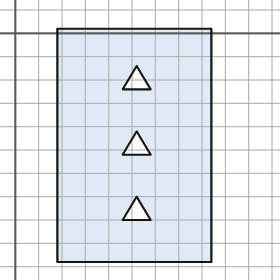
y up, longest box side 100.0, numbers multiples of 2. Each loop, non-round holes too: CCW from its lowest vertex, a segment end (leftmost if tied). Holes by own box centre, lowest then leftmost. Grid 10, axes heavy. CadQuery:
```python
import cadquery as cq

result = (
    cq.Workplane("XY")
    .moveTo(18.0, -98.0)
    .lineTo(84.0, -98.0)
    .lineTo(84.0, 2.0)
    .lineTo(18.0, 2.0)
    .close()
    .moveTo(46.0, -80.0)
    .lineTo(58.0, -80.0)
    .lineTo(52.0, -70.0)
    .close()
    .moveTo(46.0, -52.0)
    .lineTo(58.0, -52.0)
    .lineTo(52.0, -42.0)
    .close()
    .moveTo(46.0, -24.0)
    .lineTo(58.0, -24.0)
    .lineTo(52.0, -14.0)
    .close()
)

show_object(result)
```